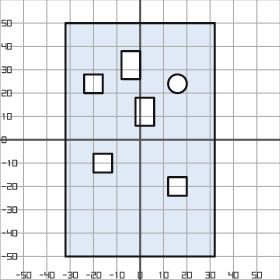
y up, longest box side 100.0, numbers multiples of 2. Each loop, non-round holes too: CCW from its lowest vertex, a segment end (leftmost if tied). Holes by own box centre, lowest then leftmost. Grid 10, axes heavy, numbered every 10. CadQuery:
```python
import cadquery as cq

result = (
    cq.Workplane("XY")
    .moveTo(-32.0, -50.0)
    .lineTo(32.0, -50.0)
    .lineTo(32.0, 50.0)
    .lineTo(-32.0, 50.0)
    .close()
    .moveTo(12.0, -24.0)
    .lineTo(20.0, -24.0)
    .lineTo(20.0, -16.0)
    .lineTo(12.0, -16.0)
    .close()
    .moveTo(-20.0, -14.0)
    .lineTo(-12.0, -14.0)
    .lineTo(-12.0, -6.0)
    .lineTo(-20.0, -6.0)
    .close()
    .moveTo(-2.0, 6.0)
    .lineTo(6.0, 6.0)
    .lineTo(6.0, 18.0)
    .lineTo(-2.0, 18.0)
    .close()
    .moveTo(-24.0, 20.0)
    .lineTo(-16.0, 20.0)
    .lineTo(-16.0, 28.0)
    .lineTo(-24.0, 28.0)
    .close()
    .moveTo(16.0, 24.0)
    .circle(4.0)
    .moveTo(-8.0, 26.0)
    .lineTo(0.0, 26.0)
    .lineTo(0.0, 38.0)
    .lineTo(-8.0, 38.0)
    .close()
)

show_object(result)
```